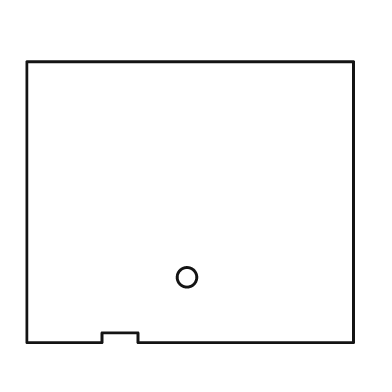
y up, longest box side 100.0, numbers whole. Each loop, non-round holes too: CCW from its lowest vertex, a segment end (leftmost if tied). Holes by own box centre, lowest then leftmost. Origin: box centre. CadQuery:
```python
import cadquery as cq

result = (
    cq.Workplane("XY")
    .moveTo(-50.0, -43.0)
    .lineTo(-27.0, -43.0)
    .lineTo(-27.0, -40.0)
    .lineTo(-16.0, -40.0)
    .lineTo(-16.0, -43.0)
    .lineTo(50.0, -43.0)
    .lineTo(50.0, 43.0)
    .lineTo(-50.0, 43.0)
    .close()
    .moveTo(-1.0, -23.0)
    .circle(3.0)
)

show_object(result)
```